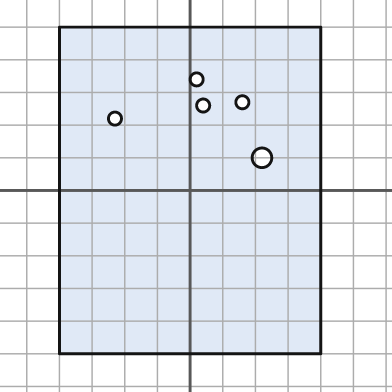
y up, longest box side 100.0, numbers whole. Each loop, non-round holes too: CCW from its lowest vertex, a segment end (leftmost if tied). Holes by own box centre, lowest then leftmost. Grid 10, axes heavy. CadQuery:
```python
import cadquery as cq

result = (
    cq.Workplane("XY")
    .moveTo(-40.0, -50.0)
    .lineTo(40.0, -50.0)
    .lineTo(40.0, 50.0)
    .lineTo(-40.0, 50.0)
    .close()
    .moveTo(22.0, 10.0)
    .circle(3.0)
    .moveTo(-23.0, 22.0)
    .circle(2.0)
    .moveTo(4.0, 26.0)
    .circle(2.0)
    .moveTo(16.0, 27.0)
    .circle(2.0)
    .moveTo(2.0, 34.0)
    .circle(2.0)
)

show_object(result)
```